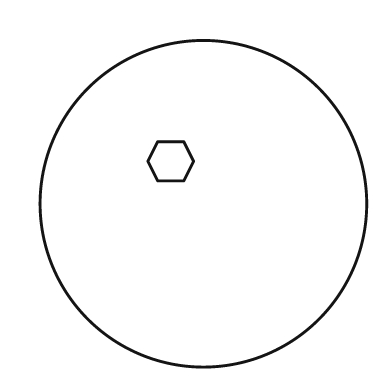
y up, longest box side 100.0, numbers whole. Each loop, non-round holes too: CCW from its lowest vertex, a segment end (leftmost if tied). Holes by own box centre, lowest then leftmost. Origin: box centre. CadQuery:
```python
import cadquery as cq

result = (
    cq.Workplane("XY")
    .moveTo(0.0, 0.0)
    .circle(50.0)
    .moveTo(-14.0, 7.0)
    .lineTo(-6.0, 7.0)
    .lineTo(-3.0, 13.0)
    .lineTo(-6.0, 19.0)
    .lineTo(-14.0, 19.0)
    .lineTo(-17.0, 13.0)
    .close()
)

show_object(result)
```